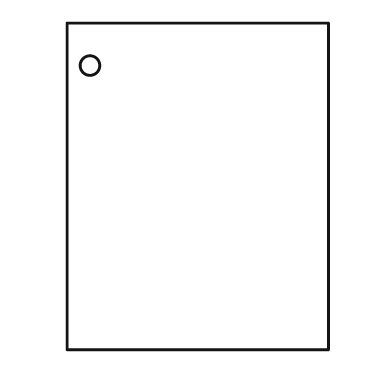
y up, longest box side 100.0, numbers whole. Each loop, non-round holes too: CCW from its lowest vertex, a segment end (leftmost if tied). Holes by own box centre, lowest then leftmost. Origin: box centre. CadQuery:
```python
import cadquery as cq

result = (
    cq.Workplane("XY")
    .moveTo(-40.0, -50.0)
    .lineTo(40.0, -50.0)
    .lineTo(40.0, 50.0)
    .lineTo(-40.0, 50.0)
    .close()
    .moveTo(-33.0, 37.0)
    .circle(3.0)
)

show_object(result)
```